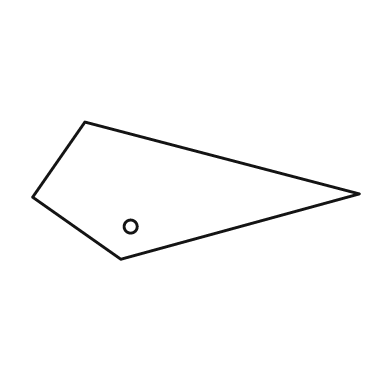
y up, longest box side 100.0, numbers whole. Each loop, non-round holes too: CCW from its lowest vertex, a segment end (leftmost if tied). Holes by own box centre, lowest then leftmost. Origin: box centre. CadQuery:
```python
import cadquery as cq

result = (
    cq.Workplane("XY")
    .moveTo(-23.0, -21.0)
    .lineTo(50.0, -1.0)
    .lineTo(-34.0, 21.0)
    .lineTo(-50.0, -2.0)
    .close()
    .moveTo(-20.0, -11.0)
    .circle(2.0)
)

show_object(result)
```